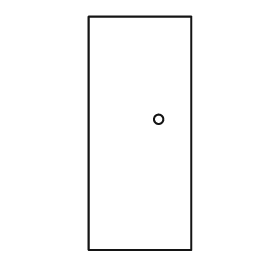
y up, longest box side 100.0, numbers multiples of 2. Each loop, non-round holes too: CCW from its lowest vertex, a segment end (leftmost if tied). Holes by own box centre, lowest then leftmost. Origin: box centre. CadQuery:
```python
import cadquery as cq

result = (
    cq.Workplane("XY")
    .moveTo(-22.0, -50.0)
    .lineTo(22.0, -50.0)
    .lineTo(22.0, 50.0)
    .lineTo(-22.0, 50.0)
    .close()
    .moveTo(8.0, 6.0)
    .circle(2.0)
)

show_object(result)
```